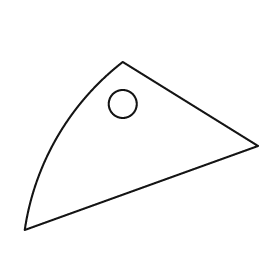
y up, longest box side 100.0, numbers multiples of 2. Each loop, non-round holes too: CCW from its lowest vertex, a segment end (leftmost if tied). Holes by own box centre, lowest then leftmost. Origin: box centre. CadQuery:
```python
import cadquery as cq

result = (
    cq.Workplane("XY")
    .moveTo(-50.0, -36.0)
    .lineTo(50.0, 0.0)
    .lineTo(-8.0, 36.0)
    .threePointArc((-36.0, 4.0), (-50.0, -36.0))
    .close()
    .moveTo(-8.0, 18.0)
    .circle(6.0)
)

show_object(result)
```